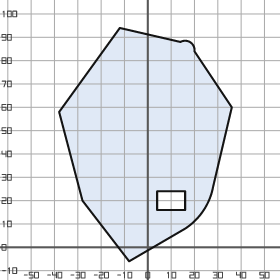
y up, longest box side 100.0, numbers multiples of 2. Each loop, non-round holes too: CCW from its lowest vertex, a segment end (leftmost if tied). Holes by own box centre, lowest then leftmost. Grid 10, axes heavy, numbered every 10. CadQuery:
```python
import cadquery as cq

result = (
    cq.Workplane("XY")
    .moveTo(-8.0, -6.0)
    .lineTo(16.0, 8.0)
    .threePointArc((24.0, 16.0), (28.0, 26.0))
    .lineTo(36.0, 60.0)
    .lineTo(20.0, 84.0)
    .threePointArc((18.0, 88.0), (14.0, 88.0))
    .lineTo(-12.0, 94.0)
    .lineTo(-38.0, 58.0)
    .lineTo(-28.0, 20.0)
    .close()
    .moveTo(4.0, 16.0)
    .lineTo(16.0, 16.0)
    .lineTo(16.0, 24.0)
    .lineTo(4.0, 24.0)
    .close()
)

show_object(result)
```